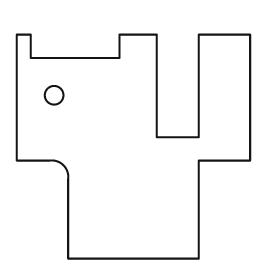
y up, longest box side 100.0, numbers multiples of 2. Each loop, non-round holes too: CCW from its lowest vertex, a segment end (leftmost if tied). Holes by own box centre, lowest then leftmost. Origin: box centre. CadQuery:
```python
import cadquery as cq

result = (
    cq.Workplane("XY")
    .moveTo(-28.0, -48.0)
    .lineTo(28.0, -48.0)
    .lineTo(28.0, -6.0)
    .lineTo(50.0, -6.0)
    .lineTo(50.0, 48.0)
    .lineTo(28.0, 48.0)
    .lineTo(28.0, 4.0)
    .lineTo(10.0, 4.0)
    .lineTo(10.0, 48.0)
    .lineTo(-6.0, 48.0)
    .lineTo(-6.0, 38.0)
    .lineTo(-44.0, 38.0)
    .lineTo(-44.0, 48.0)
    .lineTo(-50.0, 48.0)
    .lineTo(-50.0, -6.0)
    .lineTo(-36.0, -6.0)
    .threePointArc((-30.0, -8.0), (-28.0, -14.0))
    .close()
    .moveTo(-34.0, 22.0)
    .circle(4.0)
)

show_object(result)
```